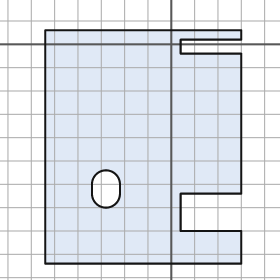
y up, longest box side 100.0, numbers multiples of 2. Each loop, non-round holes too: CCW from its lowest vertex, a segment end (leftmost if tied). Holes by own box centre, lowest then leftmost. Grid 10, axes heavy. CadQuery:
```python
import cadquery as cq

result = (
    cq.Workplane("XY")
    .moveTo(-54.0, -94.0)
    .lineTo(30.0, -94.0)
    .lineTo(30.0, -80.0)
    .lineTo(4.0, -80.0)
    .lineTo(4.0, -64.0)
    .lineTo(30.0, -64.0)
    .lineTo(30.0, -4.0)
    .lineTo(4.0, -4.0)
    .lineTo(4.0, 2.0)
    .lineTo(30.0, 2.0)
    .lineTo(30.0, 6.0)
    .lineTo(-54.0, 6.0)
    .close()
    .moveTo(-34.0, -64.0)
    .threePointArc((-28.0, -70.0), (-22.0, -64.0))
    .lineTo(-22.0, -60.0)
    .threePointArc((-28.0, -54.0), (-34.0, -60.0))
    .close()
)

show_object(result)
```